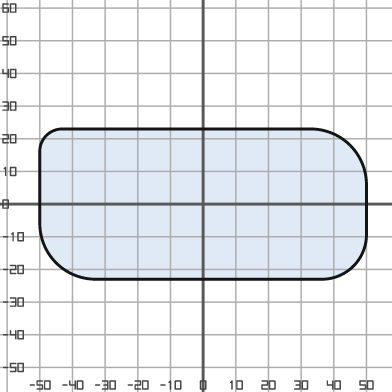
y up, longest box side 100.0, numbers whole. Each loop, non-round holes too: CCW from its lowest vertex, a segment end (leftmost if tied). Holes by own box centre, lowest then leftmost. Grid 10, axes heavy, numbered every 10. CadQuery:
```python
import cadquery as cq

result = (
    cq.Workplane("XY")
    .moveTo(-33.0, -23.0)
    .lineTo(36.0, -23.0)
    .threePointArc((46.0, -19.0), (50.0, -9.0))
    .lineTo(50.0, 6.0)
    .threePointArc((45.0, 18.0), (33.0, 23.0))
    .lineTo(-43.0, 23.0)
    .threePointArc((-48.0, 21.0), (-50.0, 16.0))
    .lineTo(-50.0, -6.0)
    .threePointArc((-45.0, -18.0), (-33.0, -23.0))
    .close()
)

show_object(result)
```